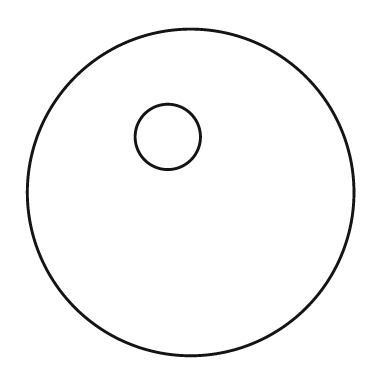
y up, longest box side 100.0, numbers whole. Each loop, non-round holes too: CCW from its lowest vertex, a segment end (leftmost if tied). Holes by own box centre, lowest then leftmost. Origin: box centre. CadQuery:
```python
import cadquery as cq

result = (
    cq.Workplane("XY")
    .moveTo(0.0, 0.0)
    .circle(50.0)
    .moveTo(-7.0, 17.0)
    .circle(10.0)
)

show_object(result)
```